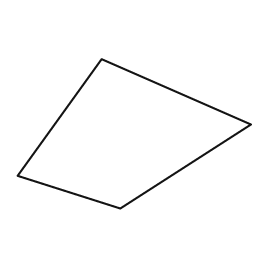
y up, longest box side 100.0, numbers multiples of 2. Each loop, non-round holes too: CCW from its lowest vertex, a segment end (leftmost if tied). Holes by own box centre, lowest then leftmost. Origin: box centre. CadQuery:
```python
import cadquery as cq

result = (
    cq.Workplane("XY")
    .moveTo(-6.0, -32.0)
    .lineTo(50.0, 4.0)
    .lineTo(-14.0, 32.0)
    .lineTo(-50.0, -18.0)
    .close()
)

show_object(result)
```